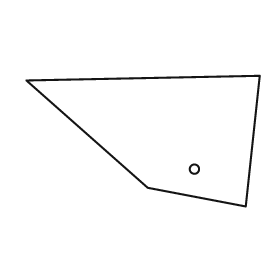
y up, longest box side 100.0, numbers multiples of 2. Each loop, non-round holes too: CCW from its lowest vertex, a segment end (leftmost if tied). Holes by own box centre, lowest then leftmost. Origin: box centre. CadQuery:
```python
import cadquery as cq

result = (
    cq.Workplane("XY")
    .moveTo(44.0, -28.0)
    .lineTo(50.0, 28.0)
    .lineTo(-50.0, 26.0)
    .lineTo(2.0, -20.0)
    .close()
    .moveTo(22.0, -12.0)
    .circle(2.0)
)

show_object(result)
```